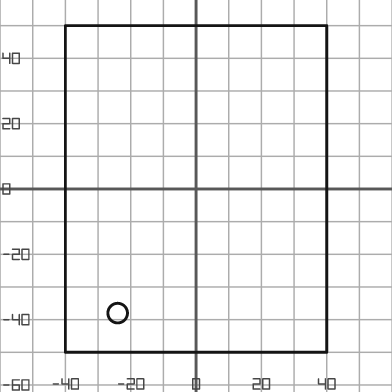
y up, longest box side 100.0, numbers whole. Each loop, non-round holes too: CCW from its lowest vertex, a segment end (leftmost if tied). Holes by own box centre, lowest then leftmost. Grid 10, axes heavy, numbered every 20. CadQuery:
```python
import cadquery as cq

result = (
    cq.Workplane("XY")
    .moveTo(-40.0, -50.0)
    .lineTo(40.0, -50.0)
    .lineTo(40.0, 50.0)
    .lineTo(-40.0, 50.0)
    .close()
    .moveTo(-24.0, -38.0)
    .circle(3.0)
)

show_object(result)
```